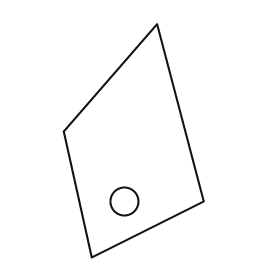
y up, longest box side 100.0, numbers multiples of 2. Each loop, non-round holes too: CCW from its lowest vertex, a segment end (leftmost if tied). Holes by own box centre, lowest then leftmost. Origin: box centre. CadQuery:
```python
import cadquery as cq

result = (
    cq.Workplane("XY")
    .moveTo(-18.0, -50.0)
    .lineTo(30.0, -26.0)
    .lineTo(10.0, 50.0)
    .lineTo(-30.0, 4.0)
    .close()
    .moveTo(-4.0, -26.0)
    .circle(6.0)
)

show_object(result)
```